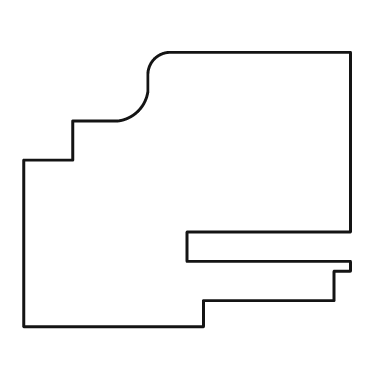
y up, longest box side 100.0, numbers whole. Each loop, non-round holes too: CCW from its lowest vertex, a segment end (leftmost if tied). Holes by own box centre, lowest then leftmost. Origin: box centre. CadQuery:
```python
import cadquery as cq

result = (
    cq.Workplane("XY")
    .moveTo(-50.0, -42.0)
    .lineTo(5.0, -42.0)
    .lineTo(5.0, -34.0)
    .lineTo(45.0, -34.0)
    .lineTo(45.0, -25.0)
    .lineTo(50.0, -25.0)
    .lineTo(50.0, -22.0)
    .lineTo(0.0, -22.0)
    .lineTo(0.0, -13.0)
    .lineTo(50.0, -13.0)
    .lineTo(50.0, 42.0)
    .lineTo(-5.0, 42.0)
    .threePointArc((-10.0, 40.0), (-12.0, 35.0))
    .lineTo(-12.0, 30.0)
    .threePointArc((-15.0, 24.0), (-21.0, 21.0))
    .lineTo(-35.0, 21.0)
    .lineTo(-35.0, 9.0)
    .lineTo(-50.0, 9.0)
    .close()
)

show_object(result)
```